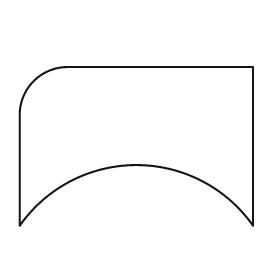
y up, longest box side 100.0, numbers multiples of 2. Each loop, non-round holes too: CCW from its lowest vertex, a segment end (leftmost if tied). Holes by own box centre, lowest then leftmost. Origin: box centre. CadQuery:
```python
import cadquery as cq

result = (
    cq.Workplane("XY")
    .moveTo(-50.0, -34.0)
    .threePointArc((0.0, -8.0), (50.0, -34.0))
    .lineTo(50.0, 34.0)
    .lineTo(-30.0, 34.0)
    .threePointArc((-44.0, 28.0), (-50.0, 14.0))
    .close()
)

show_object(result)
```